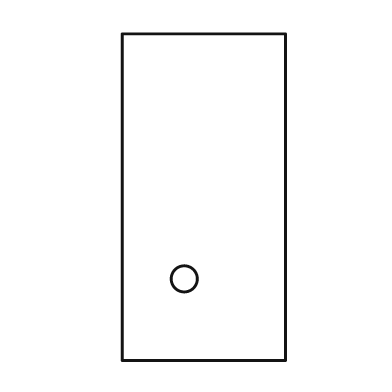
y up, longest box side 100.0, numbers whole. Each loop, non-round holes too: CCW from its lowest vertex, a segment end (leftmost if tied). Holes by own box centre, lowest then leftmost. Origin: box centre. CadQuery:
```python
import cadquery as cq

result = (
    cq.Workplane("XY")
    .moveTo(-25.0, -50.0)
    .lineTo(25.0, -50.0)
    .lineTo(25.0, 50.0)
    .lineTo(-25.0, 50.0)
    .close()
    .moveTo(-6.0, -25.0)
    .circle(4.0)
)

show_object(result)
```